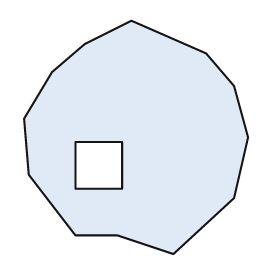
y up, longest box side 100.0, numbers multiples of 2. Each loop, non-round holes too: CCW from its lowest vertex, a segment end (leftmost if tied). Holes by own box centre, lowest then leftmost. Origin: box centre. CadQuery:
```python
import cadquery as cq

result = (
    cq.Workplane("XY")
    .moveTo(16.0, -50.0)
    .lineTo(42.0, -26.0)
    .lineTo(48.0, 0.0)
    .lineTo(42.0, 22.0)
    .lineTo(30.0, 36.0)
    .lineTo(-2.0, 50.0)
    .lineTo(-22.0, 40.0)
    .lineTo(-36.0, 28.0)
    .lineTo(-48.0, 8.0)
    .lineTo(-46.0, -16.0)
    .lineTo(-26.0, -42.0)
    .lineTo(-8.0, -42.0)
    .close()
    .moveTo(-26.0, -22.0)
    .lineTo(-6.0, -22.0)
    .lineTo(-6.0, -2.0)
    .lineTo(-26.0, -2.0)
    .close()
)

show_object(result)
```